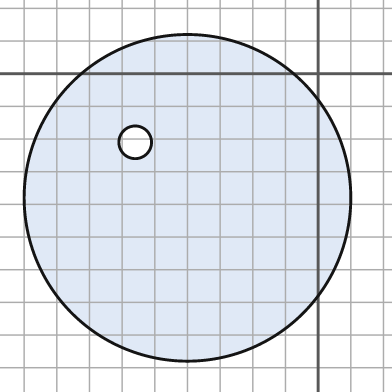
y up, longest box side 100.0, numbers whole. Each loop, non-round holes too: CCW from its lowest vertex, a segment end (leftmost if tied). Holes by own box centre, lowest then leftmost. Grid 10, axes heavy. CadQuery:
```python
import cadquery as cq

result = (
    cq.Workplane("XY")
    .moveTo(-40.0, -38.0)
    .circle(50.0)
    .moveTo(-56.0, -21.0)
    .circle(5.0)
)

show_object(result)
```